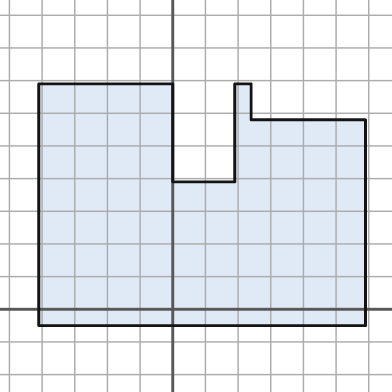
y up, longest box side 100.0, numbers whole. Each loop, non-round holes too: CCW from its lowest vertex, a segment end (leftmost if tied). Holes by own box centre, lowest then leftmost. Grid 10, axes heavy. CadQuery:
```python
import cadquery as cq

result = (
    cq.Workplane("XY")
    .moveTo(-41.0, -5.0)
    .lineTo(59.0, -5.0)
    .lineTo(59.0, 58.0)
    .lineTo(24.0, 58.0)
    .lineTo(24.0, 69.0)
    .lineTo(19.0, 69.0)
    .lineTo(19.0, 39.0)
    .lineTo(0.0, 39.0)
    .lineTo(0.0, 69.0)
    .lineTo(-41.0, 69.0)
    .close()
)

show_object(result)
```